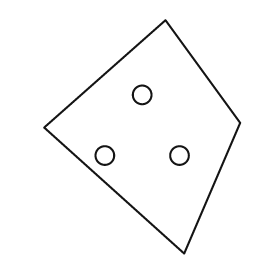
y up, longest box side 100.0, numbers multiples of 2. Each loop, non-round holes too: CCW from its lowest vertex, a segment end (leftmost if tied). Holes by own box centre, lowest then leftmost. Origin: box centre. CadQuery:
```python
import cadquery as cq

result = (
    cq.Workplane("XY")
    .moveTo(18.0, -50.0)
    .lineTo(42.0, 6.0)
    .lineTo(10.0, 50.0)
    .lineTo(-42.0, 4.0)
    .close()
    .moveTo(-16.0, -8.0)
    .circle(4.0)
    .moveTo(16.0, -8.0)
    .circle(4.0)
    .moveTo(0.0, 18.0)
    .circle(4.0)
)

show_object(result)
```